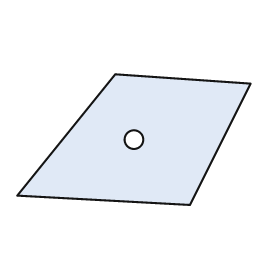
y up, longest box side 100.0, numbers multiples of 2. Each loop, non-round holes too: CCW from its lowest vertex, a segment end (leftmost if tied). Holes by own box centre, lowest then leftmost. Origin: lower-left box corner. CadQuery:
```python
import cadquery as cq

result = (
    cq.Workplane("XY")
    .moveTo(74.0, 0.0)
    .lineTo(100.0, 52.0)
    .lineTo(42.0, 56.0)
    .lineTo(0.0, 4.0)
    .close()
    .moveTo(50.0, 28.0)
    .circle(4.0)
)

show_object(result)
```